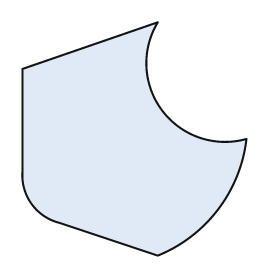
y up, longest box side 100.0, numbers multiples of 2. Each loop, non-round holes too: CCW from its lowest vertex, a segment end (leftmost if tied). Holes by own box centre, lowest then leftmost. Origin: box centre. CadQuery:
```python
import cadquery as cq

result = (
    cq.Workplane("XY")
    .moveTo(10.0, -50.0)
    .threePointArc((36.0, -30.0), (48.0, 0.0))
    .threePointArc((12.0, 12.0), (10.0, 50.0))
    .lineTo(-48.0, 30.0)
    .lineTo(-48.0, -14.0)
    .threePointArc((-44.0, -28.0), (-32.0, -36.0))
    .close()
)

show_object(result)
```